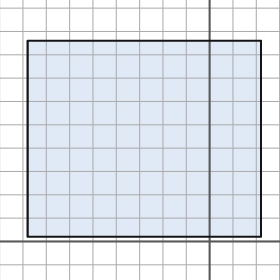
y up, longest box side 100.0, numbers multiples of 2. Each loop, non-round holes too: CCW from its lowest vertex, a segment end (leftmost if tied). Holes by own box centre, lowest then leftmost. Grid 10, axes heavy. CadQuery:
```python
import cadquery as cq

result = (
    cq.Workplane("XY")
    .moveTo(-78.0, 2.0)
    .lineTo(22.0, 2.0)
    .lineTo(22.0, 86.0)
    .lineTo(-78.0, 86.0)
    .close()
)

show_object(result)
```